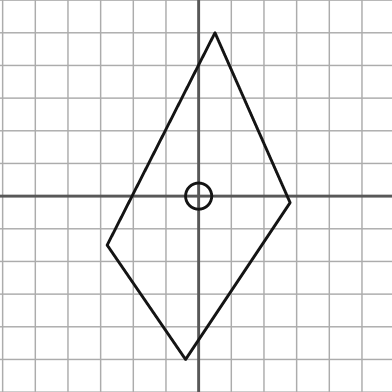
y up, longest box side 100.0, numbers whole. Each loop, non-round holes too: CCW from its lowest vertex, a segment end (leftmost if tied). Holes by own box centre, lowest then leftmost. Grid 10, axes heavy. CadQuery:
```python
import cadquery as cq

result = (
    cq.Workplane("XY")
    .moveTo(-4.0, -50.0)
    .lineTo(28.0, -2.0)
    .lineTo(5.0, 50.0)
    .lineTo(-28.0, -15.0)
    .close()
    .moveTo(0.0, 0.0)
    .circle(4.0)
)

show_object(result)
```